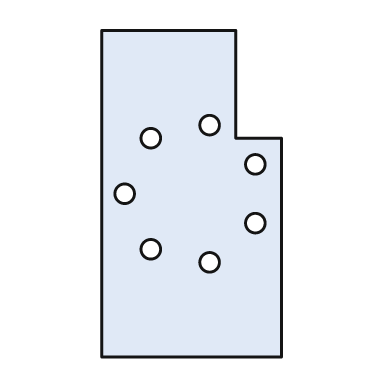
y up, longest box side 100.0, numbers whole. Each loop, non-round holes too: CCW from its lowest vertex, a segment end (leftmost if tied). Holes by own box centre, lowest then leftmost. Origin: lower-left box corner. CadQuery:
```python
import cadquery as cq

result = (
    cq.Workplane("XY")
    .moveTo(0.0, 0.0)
    .lineTo(55.0, 0.0)
    .lineTo(55.0, 67.0)
    .lineTo(41.0, 67.0)
    .lineTo(41.0, 100.0)
    .lineTo(0.0, 100.0)
    .close()
    .moveTo(33.0, 29.0)
    .circle(3.0)
    .moveTo(15.0, 33.0)
    .circle(3.0)
    .moveTo(47.0, 41.0)
    .circle(3.0)
    .moveTo(7.0, 50.0)
    .circle(3.0)
    .moveTo(47.0, 59.0)
    .circle(3.0)
    .moveTo(15.0, 67.0)
    .circle(3.0)
    .moveTo(33.0, 71.0)
    .circle(3.0)
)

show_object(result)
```